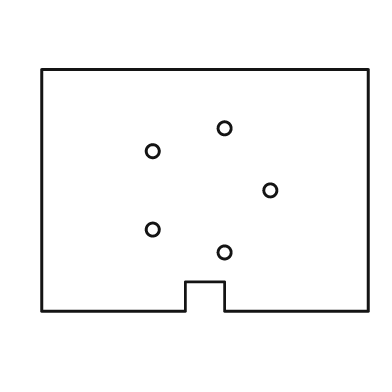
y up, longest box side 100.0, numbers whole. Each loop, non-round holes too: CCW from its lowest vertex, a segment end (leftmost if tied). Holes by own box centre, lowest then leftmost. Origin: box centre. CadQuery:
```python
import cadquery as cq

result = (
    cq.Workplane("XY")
    .moveTo(-50.0, -37.0)
    .lineTo(-6.0, -37.0)
    .lineTo(-6.0, -28.0)
    .lineTo(6.0, -28.0)
    .lineTo(6.0, -37.0)
    .lineTo(50.0, -37.0)
    .lineTo(50.0, 37.0)
    .lineTo(-50.0, 37.0)
    .close()
    .moveTo(6.0, -19.0)
    .circle(2.0)
    .moveTo(-16.0, -12.0)
    .circle(2.0)
    .moveTo(20.0, 0.0)
    .circle(2.0)
    .moveTo(-16.0, 12.0)
    .circle(2.0)
    .moveTo(6.0, 19.0)
    .circle(2.0)
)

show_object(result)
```